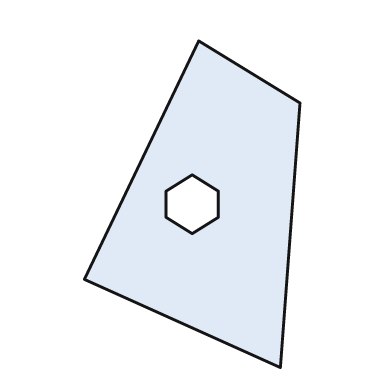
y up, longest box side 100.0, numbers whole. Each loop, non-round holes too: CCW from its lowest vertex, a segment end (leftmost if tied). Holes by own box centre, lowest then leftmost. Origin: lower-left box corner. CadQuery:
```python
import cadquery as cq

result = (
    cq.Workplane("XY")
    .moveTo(60.0, 0.0)
    .lineTo(66.0, 81.0)
    .lineTo(35.0, 100.0)
    .lineTo(0.0, 27.0)
    .close()
    .moveTo(33.0, 41.0)
    .lineTo(41.0, 46.0)
    .lineTo(41.0, 54.0)
    .lineTo(33.0, 59.0)
    .lineTo(25.0, 54.0)
    .lineTo(25.0, 46.0)
    .close()
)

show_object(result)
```